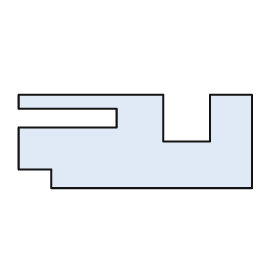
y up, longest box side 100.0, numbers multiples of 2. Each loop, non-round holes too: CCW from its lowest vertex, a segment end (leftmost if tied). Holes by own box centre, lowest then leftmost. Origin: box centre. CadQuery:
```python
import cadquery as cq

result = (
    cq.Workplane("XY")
    .moveTo(-36.0, -20.0)
    .lineTo(50.0, -20.0)
    .lineTo(50.0, 20.0)
    .lineTo(32.0, 20.0)
    .lineTo(32.0, 0.0)
    .lineTo(12.0, 0.0)
    .lineTo(12.0, 20.0)
    .lineTo(-50.0, 20.0)
    .lineTo(-50.0, 14.0)
    .lineTo(-8.0, 14.0)
    .lineTo(-8.0, 6.0)
    .lineTo(-50.0, 6.0)
    .lineTo(-50.0, -12.0)
    .lineTo(-36.0, -12.0)
    .close()
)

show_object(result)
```